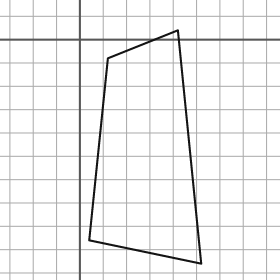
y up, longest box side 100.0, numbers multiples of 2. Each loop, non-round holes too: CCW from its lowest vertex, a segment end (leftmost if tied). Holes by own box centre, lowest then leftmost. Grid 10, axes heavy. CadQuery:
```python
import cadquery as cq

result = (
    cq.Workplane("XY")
    .moveTo(52.0, -96.0)
    .lineTo(42.0, 4.0)
    .lineTo(12.0, -8.0)
    .lineTo(4.0, -86.0)
    .close()
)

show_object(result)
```